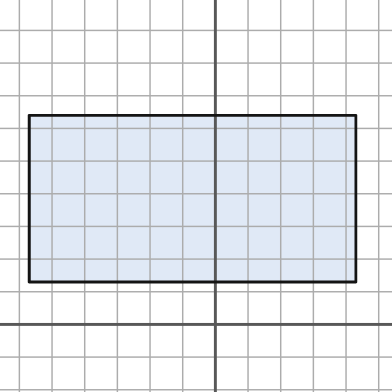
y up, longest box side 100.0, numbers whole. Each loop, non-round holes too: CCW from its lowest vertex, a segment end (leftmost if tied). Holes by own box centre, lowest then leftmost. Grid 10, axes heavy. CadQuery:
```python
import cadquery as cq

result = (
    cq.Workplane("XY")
    .moveTo(-57.0, 13.0)
    .lineTo(43.0, 13.0)
    .lineTo(43.0, 64.0)
    .lineTo(-57.0, 64.0)
    .close()
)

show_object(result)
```